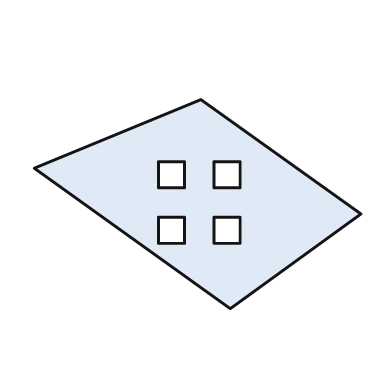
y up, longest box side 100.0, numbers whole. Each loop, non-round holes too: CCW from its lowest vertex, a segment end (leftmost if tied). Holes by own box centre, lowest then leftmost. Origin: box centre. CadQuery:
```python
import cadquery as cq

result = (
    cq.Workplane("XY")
    .moveTo(10.0, -32.0)
    .lineTo(50.0, -3.0)
    .lineTo(1.0, 32.0)
    .lineTo(-50.0, 11.0)
    .close()
    .moveTo(-12.0, -12.0)
    .lineTo(-4.0, -12.0)
    .lineTo(-4.0, -4.0)
    .lineTo(-12.0, -4.0)
    .close()
    .moveTo(5.0, -12.0)
    .lineTo(13.0, -12.0)
    .lineTo(13.0, -4.0)
    .lineTo(5.0, -4.0)
    .close()
    .moveTo(-12.0, 5.0)
    .lineTo(-4.0, 5.0)
    .lineTo(-4.0, 13.0)
    .lineTo(-12.0, 13.0)
    .close()
    .moveTo(5.0, 5.0)
    .lineTo(13.0, 5.0)
    .lineTo(13.0, 13.0)
    .lineTo(5.0, 13.0)
    .close()
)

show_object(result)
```